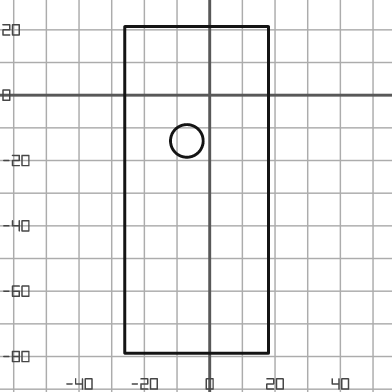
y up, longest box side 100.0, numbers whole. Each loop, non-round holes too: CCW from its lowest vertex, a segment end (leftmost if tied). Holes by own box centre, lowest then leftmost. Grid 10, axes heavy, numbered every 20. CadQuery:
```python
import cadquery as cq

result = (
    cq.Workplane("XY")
    .moveTo(-26.0, -79.0)
    .lineTo(18.0, -79.0)
    .lineTo(18.0, 21.0)
    .lineTo(-26.0, 21.0)
    .close()
    .moveTo(-7.0, -14.0)
    .circle(5.0)
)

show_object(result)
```